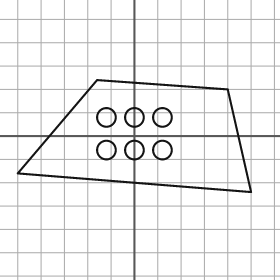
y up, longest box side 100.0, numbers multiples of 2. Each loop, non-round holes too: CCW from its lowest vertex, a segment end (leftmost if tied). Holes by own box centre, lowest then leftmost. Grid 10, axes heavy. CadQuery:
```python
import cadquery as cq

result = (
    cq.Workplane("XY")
    .moveTo(50.0, -24.0)
    .lineTo(40.0, 20.0)
    .lineTo(-16.0, 24.0)
    .lineTo(-50.0, -16.0)
    .close()
    .moveTo(-12.0, -6.0)
    .circle(4.0)
    .moveTo(0.0, -6.0)
    .circle(4.0)
    .moveTo(12.0, -6.0)
    .circle(4.0)
    .moveTo(-12.0, 8.0)
    .circle(4.0)
    .moveTo(0.0, 8.0)
    .circle(4.0)
    .moveTo(12.0, 8.0)
    .circle(4.0)
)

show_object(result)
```